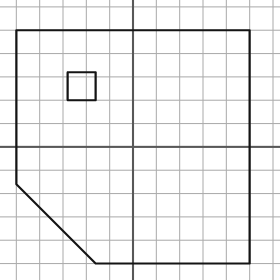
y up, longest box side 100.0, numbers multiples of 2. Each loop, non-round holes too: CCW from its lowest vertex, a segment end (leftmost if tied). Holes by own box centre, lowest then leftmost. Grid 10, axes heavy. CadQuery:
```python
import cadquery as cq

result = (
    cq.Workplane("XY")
    .moveTo(-16.0, -50.0)
    .lineTo(50.0, -50.0)
    .lineTo(50.0, 50.0)
    .lineTo(-50.0, 50.0)
    .lineTo(-50.0, -16.0)
    .close()
    .moveTo(-28.0, 20.0)
    .lineTo(-16.0, 20.0)
    .lineTo(-16.0, 32.0)
    .lineTo(-28.0, 32.0)
    .close()
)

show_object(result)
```